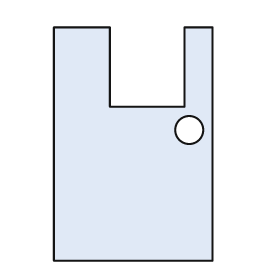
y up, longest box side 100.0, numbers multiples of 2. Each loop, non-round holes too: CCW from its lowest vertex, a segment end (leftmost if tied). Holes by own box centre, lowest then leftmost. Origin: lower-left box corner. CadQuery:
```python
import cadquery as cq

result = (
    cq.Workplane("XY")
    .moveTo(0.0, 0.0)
    .lineTo(68.0, 0.0)
    .lineTo(68.0, 100.0)
    .lineTo(56.0, 100.0)
    .lineTo(56.0, 66.0)
    .lineTo(24.0, 66.0)
    .lineTo(24.0, 100.0)
    .lineTo(0.0, 100.0)
    .close()
    .moveTo(58.0, 56.0)
    .circle(6.0)
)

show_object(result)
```